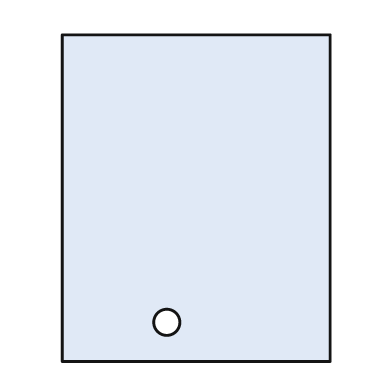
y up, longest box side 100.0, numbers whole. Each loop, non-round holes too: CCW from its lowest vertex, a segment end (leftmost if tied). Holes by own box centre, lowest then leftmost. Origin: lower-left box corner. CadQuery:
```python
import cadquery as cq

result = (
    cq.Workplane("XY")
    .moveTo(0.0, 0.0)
    .lineTo(82.0, 0.0)
    .lineTo(82.0, 100.0)
    .lineTo(0.0, 100.0)
    .close()
    .moveTo(32.0, 12.0)
    .circle(4.0)
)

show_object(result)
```